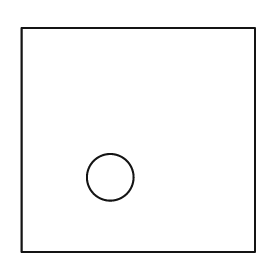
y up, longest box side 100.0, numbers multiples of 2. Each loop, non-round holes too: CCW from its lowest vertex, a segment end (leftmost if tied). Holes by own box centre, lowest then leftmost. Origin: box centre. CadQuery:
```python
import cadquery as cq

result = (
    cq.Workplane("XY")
    .moveTo(-50.0, -48.0)
    .lineTo(50.0, -48.0)
    .lineTo(50.0, 48.0)
    .lineTo(-50.0, 48.0)
    .close()
    .moveTo(-12.0, -16.0)
    .circle(10.0)
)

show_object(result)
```